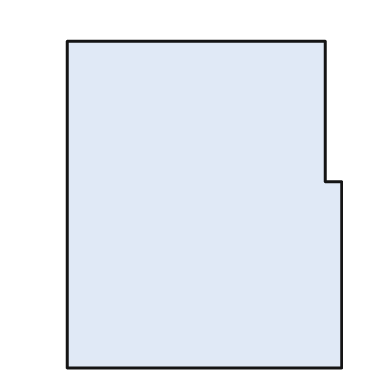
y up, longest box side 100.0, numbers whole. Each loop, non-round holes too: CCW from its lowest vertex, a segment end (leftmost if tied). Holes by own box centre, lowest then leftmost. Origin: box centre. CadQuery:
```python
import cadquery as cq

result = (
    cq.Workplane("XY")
    .moveTo(-42.0, -50.0)
    .lineTo(42.0, -50.0)
    .lineTo(42.0, 7.0)
    .lineTo(37.0, 7.0)
    .lineTo(37.0, 50.0)
    .lineTo(-42.0, 50.0)
    .close()
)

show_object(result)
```